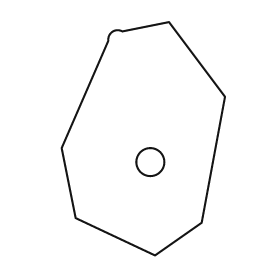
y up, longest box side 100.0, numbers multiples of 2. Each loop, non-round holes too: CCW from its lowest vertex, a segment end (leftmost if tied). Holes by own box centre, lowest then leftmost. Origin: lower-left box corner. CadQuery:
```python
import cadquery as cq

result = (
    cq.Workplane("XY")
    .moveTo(40.0, 0.0)
    .lineTo(60.0, 14.0)
    .lineTo(70.0, 68.0)
    .lineTo(46.0, 100.0)
    .lineTo(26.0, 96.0)
    .threePointArc((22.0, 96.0), (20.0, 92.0))
    .lineTo(0.0, 46.0)
    .lineTo(6.0, 16.0)
    .close()
    .moveTo(38.0, 40.0)
    .circle(6.0)
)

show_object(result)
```